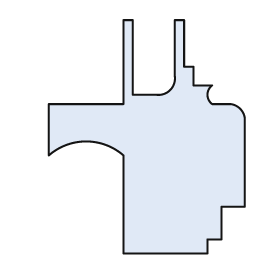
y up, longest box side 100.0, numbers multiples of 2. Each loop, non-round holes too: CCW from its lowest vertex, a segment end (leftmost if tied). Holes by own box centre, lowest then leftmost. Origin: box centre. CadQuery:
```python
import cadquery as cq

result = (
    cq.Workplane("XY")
    .moveTo(-10.0, -50.0)
    .lineTo(26.0, -50.0)
    .lineTo(26.0, -44.0)
    .lineTo(32.0, -44.0)
    .lineTo(32.0, -30.0)
    .lineTo(42.0, -30.0)
    .lineTo(42.0, 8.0)
    .threePointArc((40.0, 12.0), (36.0, 14.0))
    .lineTo(28.0, 14.0)
    .threePointArc((26.0, 18.0), (28.0, 22.0))
    .lineTo(20.0, 22.0)
    .lineTo(20.0, 30.0)
    .lineTo(16.0, 30.0)
    .lineTo(16.0, 50.0)
    .lineTo(12.0, 50.0)
    .lineTo(12.0, 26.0)
    .threePointArc((10.0, 20.0), (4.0, 18.0))
    .lineTo(-6.0, 18.0)
    .lineTo(-6.0, 50.0)
    .lineTo(-10.0, 50.0)
    .lineTo(-10.0, 14.0)
    .lineTo(-42.0, 14.0)
    .lineTo(-42.0, -8.0)
    .threePointArc((-26.0, -2.0), (-10.0, -8.0))
    .close()
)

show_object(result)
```